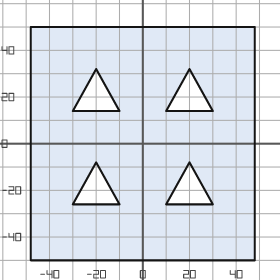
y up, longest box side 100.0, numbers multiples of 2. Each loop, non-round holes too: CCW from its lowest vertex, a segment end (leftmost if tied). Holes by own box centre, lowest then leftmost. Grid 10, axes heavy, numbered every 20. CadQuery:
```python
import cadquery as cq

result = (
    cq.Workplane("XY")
    .moveTo(-48.0, -50.0)
    .lineTo(48.0, -50.0)
    .lineTo(48.0, 50.0)
    .lineTo(-48.0, 50.0)
    .close()
    .moveTo(-30.0, -26.0)
    .lineTo(-10.0, -26.0)
    .lineTo(-20.0, -8.0)
    .close()
    .moveTo(10.0, -26.0)
    .lineTo(30.0, -26.0)
    .lineTo(20.0, -8.0)
    .close()
    .moveTo(-30.0, 14.0)
    .lineTo(-10.0, 14.0)
    .lineTo(-20.0, 32.0)
    .close()
    .moveTo(10.0, 14.0)
    .lineTo(30.0, 14.0)
    .lineTo(20.0, 32.0)
    .close()
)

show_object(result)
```